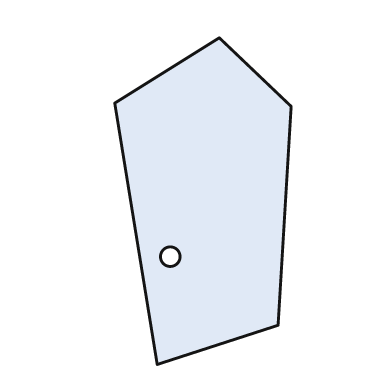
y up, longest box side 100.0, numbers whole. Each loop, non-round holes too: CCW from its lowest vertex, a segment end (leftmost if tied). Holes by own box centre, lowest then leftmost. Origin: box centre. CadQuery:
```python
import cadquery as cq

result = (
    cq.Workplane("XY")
    .moveTo(-14.0, -50.0)
    .lineTo(23.0, -38.0)
    .lineTo(27.0, 29.0)
    .lineTo(5.0, 50.0)
    .lineTo(-27.0, 30.0)
    .close()
    .moveTo(-10.0, -17.0)
    .circle(3.0)
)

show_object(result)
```